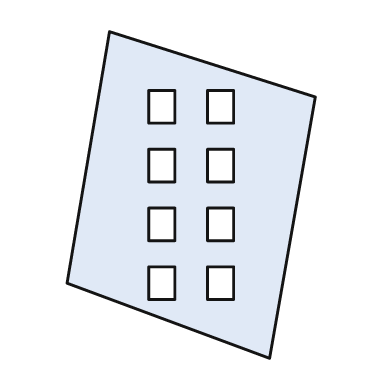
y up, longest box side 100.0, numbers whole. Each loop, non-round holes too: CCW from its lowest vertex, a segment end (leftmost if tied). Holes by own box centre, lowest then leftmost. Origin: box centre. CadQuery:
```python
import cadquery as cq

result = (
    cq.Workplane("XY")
    .moveTo(24.0, -50.0)
    .lineTo(38.0, 30.0)
    .lineTo(-25.0, 50.0)
    .lineTo(-38.0, -27.0)
    .close()
    .moveTo(-13.0, -32.0)
    .lineTo(-5.0, -32.0)
    .lineTo(-5.0, -22.0)
    .lineTo(-13.0, -22.0)
    .close()
    .moveTo(5.0, -32.0)
    .lineTo(13.0, -32.0)
    .lineTo(13.0, -22.0)
    .lineTo(5.0, -22.0)
    .close()
    .moveTo(-13.0, -14.0)
    .lineTo(-5.0, -14.0)
    .lineTo(-5.0, -4.0)
    .lineTo(-13.0, -4.0)
    .close()
    .moveTo(5.0, -14.0)
    .lineTo(13.0, -14.0)
    .lineTo(13.0, -4.0)
    .lineTo(5.0, -4.0)
    .close()
    .moveTo(-13.0, 4.0)
    .lineTo(-5.0, 4.0)
    .lineTo(-5.0, 14.0)
    .lineTo(-13.0, 14.0)
    .close()
    .moveTo(5.0, 4.0)
    .lineTo(13.0, 4.0)
    .lineTo(13.0, 14.0)
    .lineTo(5.0, 14.0)
    .close()
    .moveTo(-13.0, 22.0)
    .lineTo(-5.0, 22.0)
    .lineTo(-5.0, 32.0)
    .lineTo(-13.0, 32.0)
    .close()
    .moveTo(5.0, 22.0)
    .lineTo(13.0, 22.0)
    .lineTo(13.0, 32.0)
    .lineTo(5.0, 32.0)
    .close()
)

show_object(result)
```